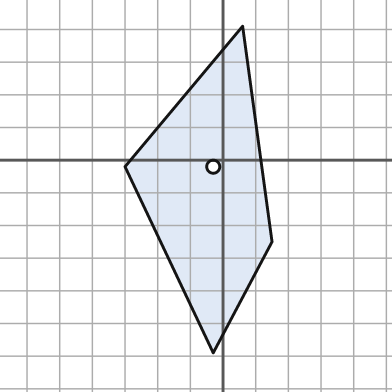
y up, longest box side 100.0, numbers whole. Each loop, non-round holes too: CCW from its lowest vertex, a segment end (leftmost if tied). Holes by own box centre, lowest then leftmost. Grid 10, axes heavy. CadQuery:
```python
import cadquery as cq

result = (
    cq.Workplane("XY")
    .moveTo(-3.0, -59.0)
    .lineTo(15.0, -25.0)
    .lineTo(6.0, 41.0)
    .lineTo(-30.0, -2.0)
    .close()
    .moveTo(-3.0, -2.0)
    .circle(2.0)
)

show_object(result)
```